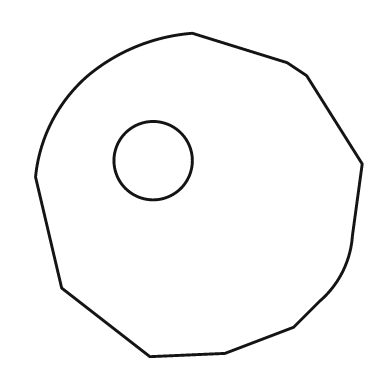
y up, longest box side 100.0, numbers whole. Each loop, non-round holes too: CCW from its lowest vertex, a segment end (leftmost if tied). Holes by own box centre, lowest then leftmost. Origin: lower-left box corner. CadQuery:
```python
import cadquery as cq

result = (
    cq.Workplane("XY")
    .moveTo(35.0, 0.0)
    .lineTo(58.0, 1.0)
    .lineTo(79.0, 9.0)
    .lineTo(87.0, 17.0)
    .threePointArc((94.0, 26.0), (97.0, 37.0))
    .lineTo(100.0, 59.0)
    .lineTo(83.0, 86.0)
    .lineTo(77.0, 90.0)
    .lineTo(48.0, 99.0)
    .threePointArc((31.0, 95.0), (16.0, 86.0))
    .threePointArc((5.0, 72.0), (0.0, 55.0))
    .lineTo(8.0, 21.0)
    .close()
    .moveTo(36.0, 60.0)
    .circle(12.0)
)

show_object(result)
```